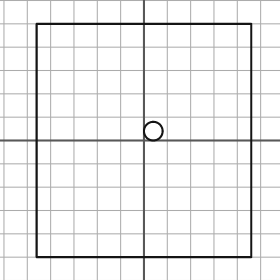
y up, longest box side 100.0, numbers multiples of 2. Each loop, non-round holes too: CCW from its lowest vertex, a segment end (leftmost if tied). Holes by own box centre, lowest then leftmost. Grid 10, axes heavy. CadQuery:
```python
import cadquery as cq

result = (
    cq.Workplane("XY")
    .moveTo(-46.0, -50.0)
    .lineTo(46.0, -50.0)
    .lineTo(46.0, 50.0)
    .lineTo(-46.0, 50.0)
    .close()
    .moveTo(4.0, 4.0)
    .circle(4.0)
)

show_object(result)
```